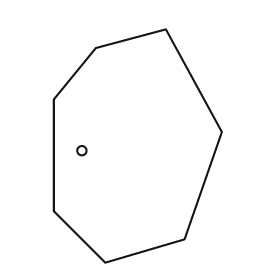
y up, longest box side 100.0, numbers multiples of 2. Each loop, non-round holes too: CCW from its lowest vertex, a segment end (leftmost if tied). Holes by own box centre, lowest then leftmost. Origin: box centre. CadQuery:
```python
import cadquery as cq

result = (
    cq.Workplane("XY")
    .moveTo(-14.0, -50.0)
    .lineTo(20.0, -40.0)
    .lineTo(36.0, 6.0)
    .lineTo(12.0, 50.0)
    .lineTo(-18.0, 42.0)
    .lineTo(-36.0, 20.0)
    .lineTo(-36.0, -28.0)
    .close()
    .moveTo(-24.0, -2.0)
    .circle(2.0)
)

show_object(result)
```